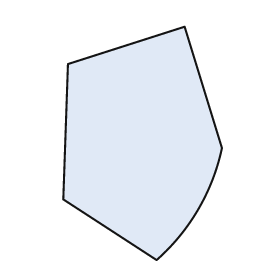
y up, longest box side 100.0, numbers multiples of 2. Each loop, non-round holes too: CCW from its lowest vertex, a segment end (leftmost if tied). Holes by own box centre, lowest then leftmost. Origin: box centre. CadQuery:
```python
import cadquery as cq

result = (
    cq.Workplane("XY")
    .moveTo(6.0, -50.0)
    .threePointArc((24.0, -28.0), (34.0, -2.0))
    .lineTo(18.0, 50.0)
    .lineTo(-32.0, 34.0)
    .lineTo(-34.0, -24.0)
    .close()
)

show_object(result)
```